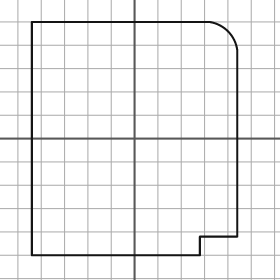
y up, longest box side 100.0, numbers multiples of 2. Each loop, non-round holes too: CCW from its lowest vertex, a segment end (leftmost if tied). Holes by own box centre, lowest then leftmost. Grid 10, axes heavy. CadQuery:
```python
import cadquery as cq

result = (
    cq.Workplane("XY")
    .moveTo(-44.0, -50.0)
    .lineTo(28.0, -50.0)
    .lineTo(28.0, -42.0)
    .lineTo(44.0, -42.0)
    .lineTo(44.0, 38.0)
    .threePointArc((40.0, 46.0), (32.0, 50.0))
    .lineTo(-44.0, 50.0)
    .close()
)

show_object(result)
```